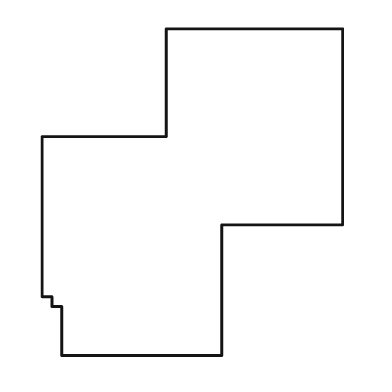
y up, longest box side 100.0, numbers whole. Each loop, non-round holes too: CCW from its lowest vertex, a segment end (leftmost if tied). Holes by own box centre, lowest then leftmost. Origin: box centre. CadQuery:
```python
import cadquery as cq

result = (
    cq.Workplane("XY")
    .moveTo(-40.0, -50.0)
    .lineTo(9.0, -50.0)
    .lineTo(9.0, -10.0)
    .lineTo(46.0, -10.0)
    .lineTo(46.0, 50.0)
    .lineTo(-8.0, 50.0)
    .lineTo(-8.0, 17.0)
    .lineTo(-46.0, 17.0)
    .lineTo(-46.0, -32.0)
    .lineTo(-43.0, -32.0)
    .lineTo(-43.0, -35.0)
    .lineTo(-40.0, -35.0)
    .close()
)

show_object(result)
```